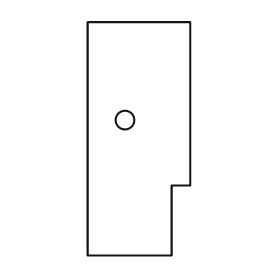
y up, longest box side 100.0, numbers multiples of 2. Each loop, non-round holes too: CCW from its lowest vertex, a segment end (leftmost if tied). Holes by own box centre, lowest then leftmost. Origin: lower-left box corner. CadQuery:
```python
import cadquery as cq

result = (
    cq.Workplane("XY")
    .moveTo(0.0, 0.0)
    .lineTo(36.0, 0.0)
    .lineTo(36.0, 30.0)
    .lineTo(44.0, 30.0)
    .lineTo(44.0, 100.0)
    .lineTo(0.0, 100.0)
    .close()
    .moveTo(16.0, 58.0)
    .circle(4.0)
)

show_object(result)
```